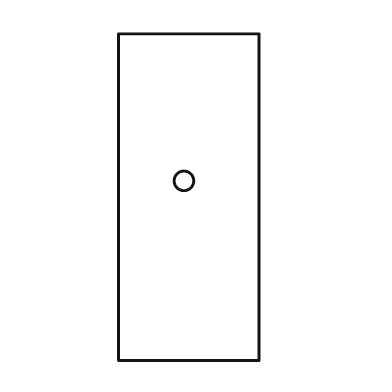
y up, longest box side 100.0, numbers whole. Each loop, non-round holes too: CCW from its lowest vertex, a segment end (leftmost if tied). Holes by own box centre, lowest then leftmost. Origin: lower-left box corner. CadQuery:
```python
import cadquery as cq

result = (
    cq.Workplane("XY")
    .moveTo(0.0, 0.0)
    .lineTo(43.0, 0.0)
    .lineTo(43.0, 100.0)
    .lineTo(0.0, 100.0)
    .close()
    .moveTo(20.0, 55.0)
    .circle(3.0)
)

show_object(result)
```